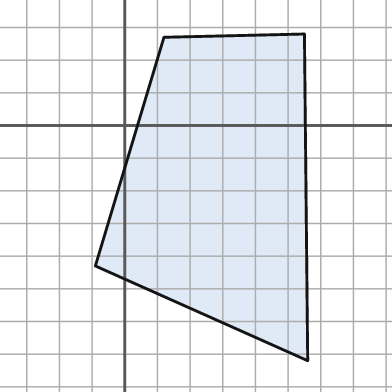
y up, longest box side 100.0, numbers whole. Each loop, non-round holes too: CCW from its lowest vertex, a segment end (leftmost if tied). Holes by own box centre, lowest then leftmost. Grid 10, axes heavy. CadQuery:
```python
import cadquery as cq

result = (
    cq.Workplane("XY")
    .moveTo(56.0, -72.0)
    .lineTo(55.0, 28.0)
    .lineTo(12.0, 27.0)
    .lineTo(-9.0, -43.0)
    .close()
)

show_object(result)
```